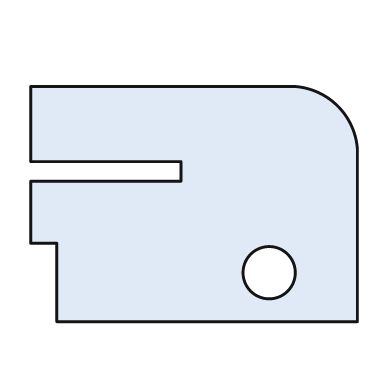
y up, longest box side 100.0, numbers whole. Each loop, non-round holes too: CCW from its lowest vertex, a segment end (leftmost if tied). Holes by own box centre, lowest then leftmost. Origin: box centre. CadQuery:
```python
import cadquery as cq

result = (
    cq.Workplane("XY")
    .moveTo(-42.0, -36.0)
    .lineTo(50.0, -36.0)
    .lineTo(50.0, 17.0)
    .threePointArc((44.0, 30.0), (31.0, 36.0))
    .lineTo(-50.0, 36.0)
    .lineTo(-50.0, 13.0)
    .lineTo(-4.0, 13.0)
    .lineTo(-4.0, 7.0)
    .lineTo(-50.0, 7.0)
    .lineTo(-50.0, -12.0)
    .lineTo(-42.0, -12.0)
    .close()
    .moveTo(23.0, -21.0)
    .circle(8.0)
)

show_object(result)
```